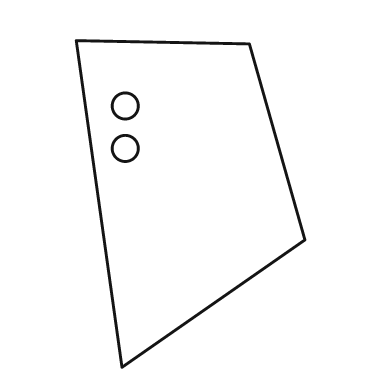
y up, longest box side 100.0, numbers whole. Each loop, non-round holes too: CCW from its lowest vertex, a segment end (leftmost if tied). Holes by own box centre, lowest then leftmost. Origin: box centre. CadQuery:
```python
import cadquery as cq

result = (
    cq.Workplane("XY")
    .moveTo(-21.0, -50.0)
    .lineTo(35.0, -11.0)
    .lineTo(18.0, 49.0)
    .lineTo(-35.0, 50.0)
    .close()
    .moveTo(-20.0, 17.0)
    .circle(4.0)
    .moveTo(-20.0, 30.0)
    .circle(4.0)
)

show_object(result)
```